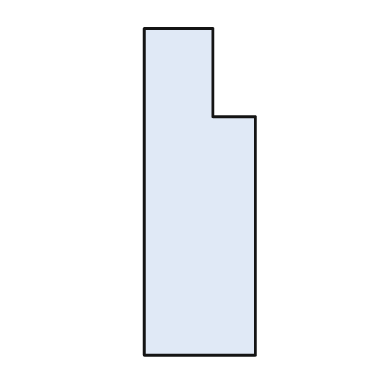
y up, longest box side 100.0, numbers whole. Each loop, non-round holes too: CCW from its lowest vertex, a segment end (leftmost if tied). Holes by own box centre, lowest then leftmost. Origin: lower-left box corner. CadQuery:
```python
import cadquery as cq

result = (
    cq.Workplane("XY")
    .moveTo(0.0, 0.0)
    .lineTo(34.0, 0.0)
    .lineTo(34.0, 73.0)
    .lineTo(21.0, 73.0)
    .lineTo(21.0, 100.0)
    .lineTo(0.0, 100.0)
    .close()
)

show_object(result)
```